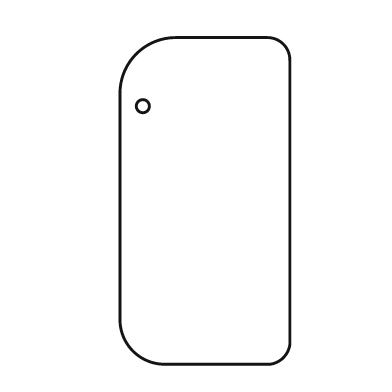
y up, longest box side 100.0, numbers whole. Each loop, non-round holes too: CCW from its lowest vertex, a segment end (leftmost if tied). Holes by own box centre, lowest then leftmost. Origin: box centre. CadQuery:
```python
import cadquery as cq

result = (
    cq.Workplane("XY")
    .moveTo(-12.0, -50.0)
    .lineTo(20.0, -50.0)
    .threePointArc((24.0, -48.0), (26.0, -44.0))
    .lineTo(26.0, 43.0)
    .threePointArc((24.0, 48.0), (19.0, 50.0))
    .lineTo(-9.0, 50.0)
    .threePointArc((-21.0, 45.0), (-26.0, 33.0))
    .lineTo(-26.0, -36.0)
    .threePointArc((-22.0, -46.0), (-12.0, -50.0))
    .close()
    .moveTo(-19.0, 29.0)
    .circle(2.0)
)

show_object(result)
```